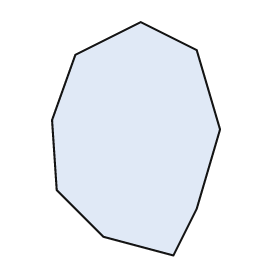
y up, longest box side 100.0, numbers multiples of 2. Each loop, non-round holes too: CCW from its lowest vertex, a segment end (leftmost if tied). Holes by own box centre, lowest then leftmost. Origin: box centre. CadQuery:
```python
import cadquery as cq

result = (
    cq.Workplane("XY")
    .moveTo(16.0, -50.0)
    .lineTo(26.0, -30.0)
    .lineTo(36.0, 4.0)
    .lineTo(26.0, 38.0)
    .lineTo(2.0, 50.0)
    .lineTo(-26.0, 36.0)
    .lineTo(-36.0, 8.0)
    .lineTo(-34.0, -22.0)
    .lineTo(-14.0, -42.0)
    .close()
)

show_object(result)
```